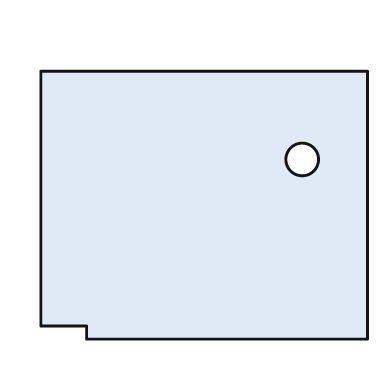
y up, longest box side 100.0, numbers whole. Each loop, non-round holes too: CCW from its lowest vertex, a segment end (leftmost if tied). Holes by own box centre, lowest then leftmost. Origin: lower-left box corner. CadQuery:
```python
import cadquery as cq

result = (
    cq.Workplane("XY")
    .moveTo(14.0, 0.0)
    .lineTo(100.0, 0.0)
    .lineTo(100.0, 82.0)
    .lineTo(0.0, 82.0)
    .lineTo(0.0, 4.0)
    .lineTo(14.0, 4.0)
    .close()
    .moveTo(80.0, 55.0)
    .circle(5.0)
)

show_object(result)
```